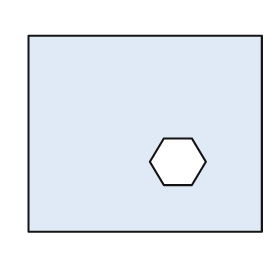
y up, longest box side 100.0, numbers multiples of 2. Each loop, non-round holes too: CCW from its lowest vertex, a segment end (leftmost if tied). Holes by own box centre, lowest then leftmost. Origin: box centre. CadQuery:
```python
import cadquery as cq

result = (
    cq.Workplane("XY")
    .moveTo(-50.0, -42.0)
    .lineTo(50.0, -42.0)
    .lineTo(50.0, 42.0)
    .lineTo(-50.0, 42.0)
    .close()
    .moveTo(8.0, -22.0)
    .lineTo(20.0, -22.0)
    .lineTo(26.0, -12.0)
    .lineTo(20.0, -2.0)
    .lineTo(8.0, -2.0)
    .lineTo(2.0, -12.0)
    .close()
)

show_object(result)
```